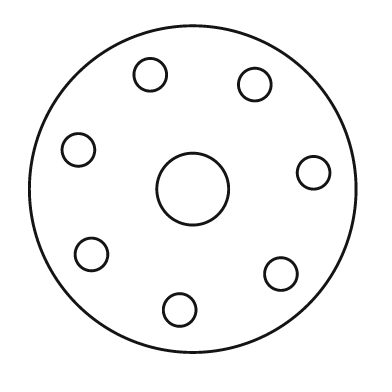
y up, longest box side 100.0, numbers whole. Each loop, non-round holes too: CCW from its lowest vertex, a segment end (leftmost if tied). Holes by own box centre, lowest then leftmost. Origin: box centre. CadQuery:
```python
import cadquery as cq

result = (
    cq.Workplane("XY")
    .moveTo(0.0, 0.0)
    .circle(50.0)
    .moveTo(-4.0, -37.0)
    .circle(5.0)
    .moveTo(27.0, -26.0)
    .circle(5.0)
    .moveTo(-31.0, -20.0)
    .circle(5.0)
    .moveTo(0.0, 0.0)
    .circle(11.0)
    .moveTo(37.0, 5.0)
    .circle(5.0)
    .moveTo(-35.0, 12.0)
    .circle(5.0)
    .moveTo(19.0, 32.0)
    .circle(5.0)
    .moveTo(-13.0, 35.0)
    .circle(5.0)
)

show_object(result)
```